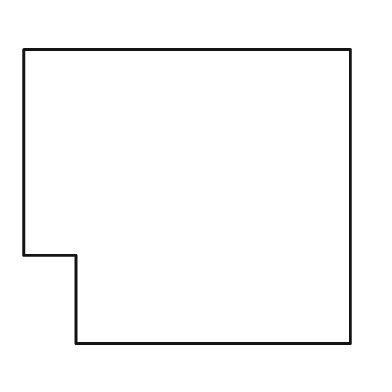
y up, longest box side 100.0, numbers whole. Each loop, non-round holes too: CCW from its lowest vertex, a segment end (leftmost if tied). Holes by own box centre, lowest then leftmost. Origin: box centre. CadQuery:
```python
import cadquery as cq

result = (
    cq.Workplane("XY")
    .moveTo(-34.0, -45.0)
    .lineTo(50.0, -45.0)
    .lineTo(50.0, 45.0)
    .lineTo(-50.0, 45.0)
    .lineTo(-50.0, -18.0)
    .lineTo(-34.0, -18.0)
    .close()
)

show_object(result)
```